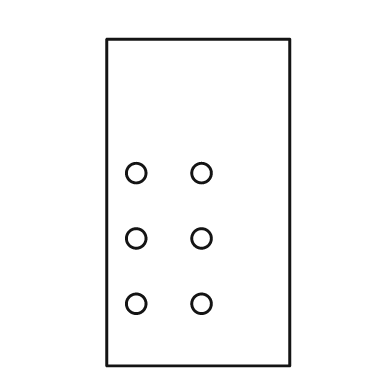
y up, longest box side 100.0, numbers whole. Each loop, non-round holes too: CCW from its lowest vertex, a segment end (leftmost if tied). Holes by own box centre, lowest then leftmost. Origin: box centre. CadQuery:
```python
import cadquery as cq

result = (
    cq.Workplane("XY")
    .moveTo(-28.0, -50.0)
    .lineTo(28.0, -50.0)
    .lineTo(28.0, 50.0)
    .lineTo(-28.0, 50.0)
    .close()
    .moveTo(-19.0, -31.0)
    .circle(3.0)
    .moveTo(1.0, -31.0)
    .circle(3.0)
    .moveTo(-19.0, -11.0)
    .circle(3.0)
    .moveTo(1.0, -11.0)
    .circle(3.0)
    .moveTo(-19.0, 9.0)
    .circle(3.0)
    .moveTo(1.0, 9.0)
    .circle(3.0)
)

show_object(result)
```